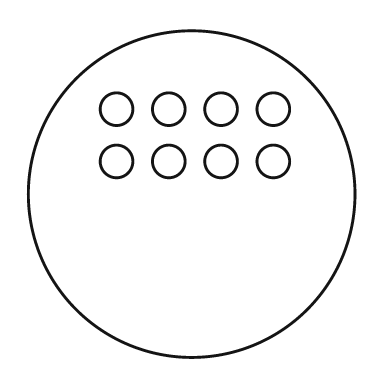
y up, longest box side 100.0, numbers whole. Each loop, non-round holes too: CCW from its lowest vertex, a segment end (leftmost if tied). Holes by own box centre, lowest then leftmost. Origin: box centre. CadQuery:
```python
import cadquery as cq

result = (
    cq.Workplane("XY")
    .moveTo(0.0, 0.0)
    .circle(50.0)
    .moveTo(-23.0, 10.0)
    .circle(5.0)
    .moveTo(-7.0, 10.0)
    .circle(5.0)
    .moveTo(9.0, 10.0)
    .circle(5.0)
    .moveTo(25.0, 10.0)
    .circle(5.0)
    .moveTo(-23.0, 26.0)
    .circle(5.0)
    .moveTo(-7.0, 26.0)
    .circle(5.0)
    .moveTo(9.0, 26.0)
    .circle(5.0)
    .moveTo(25.0, 26.0)
    .circle(5.0)
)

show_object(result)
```